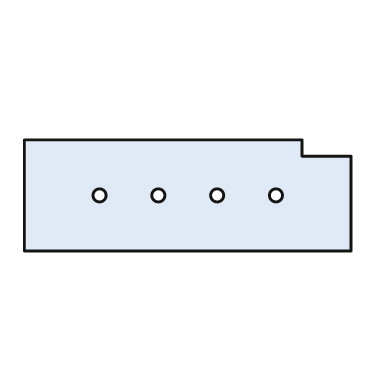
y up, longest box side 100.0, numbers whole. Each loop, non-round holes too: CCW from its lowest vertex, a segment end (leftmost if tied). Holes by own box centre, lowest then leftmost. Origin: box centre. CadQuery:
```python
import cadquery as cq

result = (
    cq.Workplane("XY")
    .moveTo(-50.0, -17.0)
    .lineTo(50.0, -17.0)
    .lineTo(50.0, 12.0)
    .lineTo(35.0, 12.0)
    .lineTo(35.0, 17.0)
    .lineTo(-50.0, 17.0)
    .close()
    .moveTo(-27.0, 0.0)
    .circle(2.0)
    .moveTo(-9.0, 0.0)
    .circle(2.0)
    .moveTo(9.0, 0.0)
    .circle(2.0)
    .moveTo(27.0, 0.0)
    .circle(2.0)
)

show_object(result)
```